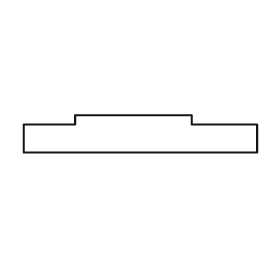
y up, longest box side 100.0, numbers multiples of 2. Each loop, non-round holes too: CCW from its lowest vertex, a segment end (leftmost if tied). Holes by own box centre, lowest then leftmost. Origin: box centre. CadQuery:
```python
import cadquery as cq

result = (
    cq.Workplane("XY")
    .moveTo(-50.0, -8.0)
    .lineTo(50.0, -8.0)
    .lineTo(50.0, 4.0)
    .lineTo(22.0, 4.0)
    .lineTo(22.0, 8.0)
    .lineTo(-28.0, 8.0)
    .lineTo(-28.0, 4.0)
    .lineTo(-50.0, 4.0)
    .close()
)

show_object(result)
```